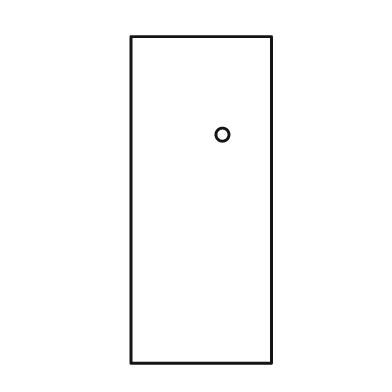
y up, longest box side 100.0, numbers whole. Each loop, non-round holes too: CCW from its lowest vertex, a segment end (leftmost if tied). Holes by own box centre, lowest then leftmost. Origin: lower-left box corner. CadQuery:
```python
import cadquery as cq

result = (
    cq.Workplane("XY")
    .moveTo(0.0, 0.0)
    .lineTo(43.0, 0.0)
    .lineTo(43.0, 100.0)
    .lineTo(0.0, 100.0)
    .close()
    .moveTo(28.0, 70.0)
    .circle(2.0)
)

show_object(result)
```